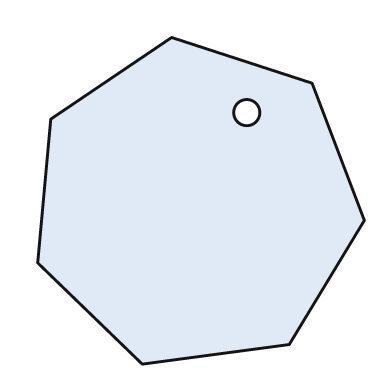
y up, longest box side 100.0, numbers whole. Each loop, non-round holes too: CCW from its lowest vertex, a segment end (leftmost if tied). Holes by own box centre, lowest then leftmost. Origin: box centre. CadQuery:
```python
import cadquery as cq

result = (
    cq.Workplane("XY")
    .moveTo(-18.0, -50.0)
    .lineTo(27.0, -44.0)
    .lineTo(50.0, -6.0)
    .lineTo(34.0, 36.0)
    .lineTo(-9.0, 50.0)
    .lineTo(-46.0, 25.0)
    .lineTo(-50.0, -19.0)
    .close()
    .moveTo(14.0, 27.0)
    .circle(4.0)
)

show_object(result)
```